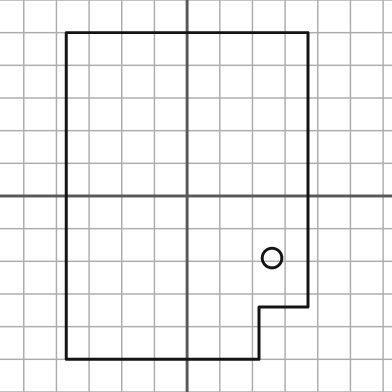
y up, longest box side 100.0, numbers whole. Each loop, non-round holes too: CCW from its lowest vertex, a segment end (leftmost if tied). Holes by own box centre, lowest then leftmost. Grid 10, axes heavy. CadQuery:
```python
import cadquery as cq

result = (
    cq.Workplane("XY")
    .moveTo(-37.0, -50.0)
    .lineTo(22.0, -50.0)
    .lineTo(22.0, -34.0)
    .lineTo(37.0, -34.0)
    .lineTo(37.0, 50.0)
    .lineTo(-37.0, 50.0)
    .close()
    .moveTo(26.0, -19.0)
    .circle(3.0)
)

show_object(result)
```